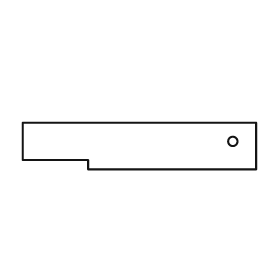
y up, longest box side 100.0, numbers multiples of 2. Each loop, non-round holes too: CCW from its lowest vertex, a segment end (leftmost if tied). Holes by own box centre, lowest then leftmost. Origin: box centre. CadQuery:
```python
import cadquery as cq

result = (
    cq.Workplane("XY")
    .moveTo(-22.0, -10.0)
    .lineTo(50.0, -10.0)
    .lineTo(50.0, 10.0)
    .lineTo(-50.0, 10.0)
    .lineTo(-50.0, -6.0)
    .lineTo(-22.0, -6.0)
    .close()
    .moveTo(40.0, 2.0)
    .circle(2.0)
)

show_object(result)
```